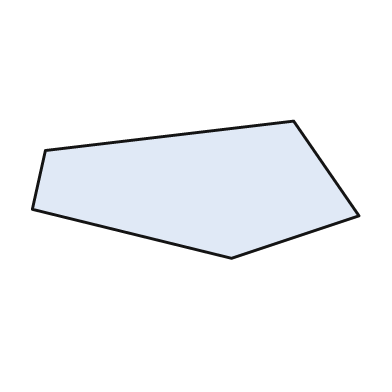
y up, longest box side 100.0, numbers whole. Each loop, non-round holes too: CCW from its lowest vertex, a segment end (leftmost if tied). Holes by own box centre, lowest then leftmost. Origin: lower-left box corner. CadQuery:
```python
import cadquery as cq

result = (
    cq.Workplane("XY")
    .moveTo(61.0, 0.0)
    .lineTo(100.0, 13.0)
    .lineTo(80.0, 42.0)
    .lineTo(4.0, 33.0)
    .lineTo(0.0, 15.0)
    .close()
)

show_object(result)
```